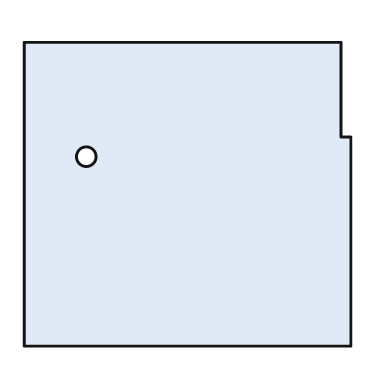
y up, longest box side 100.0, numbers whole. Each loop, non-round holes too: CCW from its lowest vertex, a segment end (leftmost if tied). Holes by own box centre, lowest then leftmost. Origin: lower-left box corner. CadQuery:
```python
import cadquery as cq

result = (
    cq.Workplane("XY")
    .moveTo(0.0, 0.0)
    .lineTo(100.0, 0.0)
    .lineTo(100.0, 64.0)
    .lineTo(97.0, 64.0)
    .lineTo(97.0, 93.0)
    .lineTo(0.0, 93.0)
    .close()
    .moveTo(19.0, 58.0)
    .circle(3.0)
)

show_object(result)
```